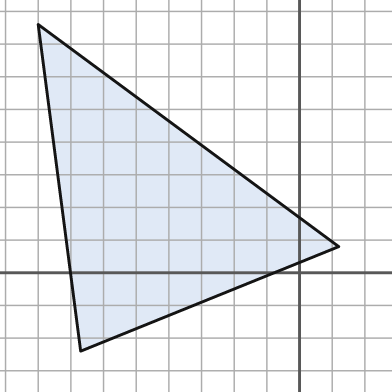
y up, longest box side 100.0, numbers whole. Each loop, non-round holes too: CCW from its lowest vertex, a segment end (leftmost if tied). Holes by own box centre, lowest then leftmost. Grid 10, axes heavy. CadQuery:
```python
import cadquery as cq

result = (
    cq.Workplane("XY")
    .moveTo(-67.0, -24.0)
    .lineTo(12.0, 8.0)
    .lineTo(-80.0, 76.0)
    .close()
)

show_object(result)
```